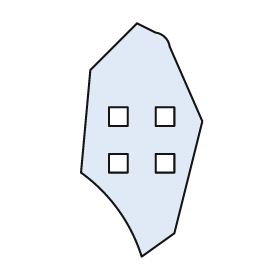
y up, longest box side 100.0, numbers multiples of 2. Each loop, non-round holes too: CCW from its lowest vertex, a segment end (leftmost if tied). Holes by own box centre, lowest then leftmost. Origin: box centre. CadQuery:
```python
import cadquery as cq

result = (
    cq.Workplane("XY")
    .moveTo(0.0, -50.0)
    .lineTo(14.0, -40.0)
    .lineTo(26.0, 8.0)
    .lineTo(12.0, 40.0)
    .threePointArc((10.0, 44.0), (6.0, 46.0))
    .lineTo(-2.0, 50.0)
    .lineTo(-22.0, 30.0)
    .lineTo(-26.0, -14.0)
    .threePointArc((-10.0, -30.0), (0.0, -50.0))
    .close()
    .moveTo(-14.0, -14.0)
    .lineTo(-6.0, -14.0)
    .lineTo(-6.0, -6.0)
    .lineTo(-14.0, -6.0)
    .close()
    .moveTo(6.0, -14.0)
    .lineTo(14.0, -14.0)
    .lineTo(14.0, -6.0)
    .lineTo(6.0, -6.0)
    .close()
    .moveTo(-14.0, 6.0)
    .lineTo(-6.0, 6.0)
    .lineTo(-6.0, 14.0)
    .lineTo(-14.0, 14.0)
    .close()
    .moveTo(6.0, 6.0)
    .lineTo(14.0, 6.0)
    .lineTo(14.0, 14.0)
    .lineTo(6.0, 14.0)
    .close()
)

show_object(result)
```